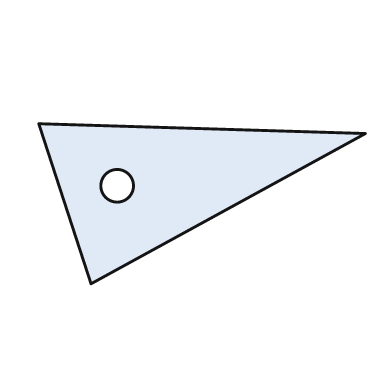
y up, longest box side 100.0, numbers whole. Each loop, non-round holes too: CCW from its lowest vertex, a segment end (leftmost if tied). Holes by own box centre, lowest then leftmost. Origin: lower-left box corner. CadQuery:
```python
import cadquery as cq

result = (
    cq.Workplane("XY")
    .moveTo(16.0, 0.0)
    .lineTo(100.0, 46.0)
    .lineTo(0.0, 49.0)
    .close()
    .moveTo(24.0, 30.0)
    .circle(5.0)
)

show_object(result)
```